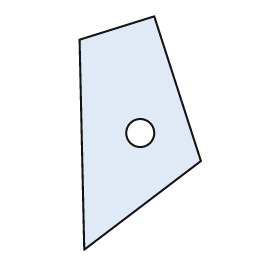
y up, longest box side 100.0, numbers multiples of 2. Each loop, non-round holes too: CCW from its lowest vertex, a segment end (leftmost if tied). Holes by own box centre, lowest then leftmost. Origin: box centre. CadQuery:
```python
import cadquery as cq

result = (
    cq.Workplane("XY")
    .moveTo(-24.0, -50.0)
    .lineTo(26.0, -12.0)
    .lineTo(6.0, 50.0)
    .lineTo(-26.0, 40.0)
    .close()
    .moveTo(0.0, 0.0)
    .circle(6.0)
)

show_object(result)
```